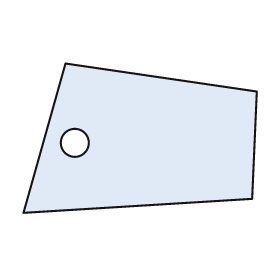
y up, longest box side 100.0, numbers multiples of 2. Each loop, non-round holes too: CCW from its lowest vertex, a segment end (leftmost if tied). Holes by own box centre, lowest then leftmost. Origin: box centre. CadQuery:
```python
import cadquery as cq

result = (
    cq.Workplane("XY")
    .moveTo(-50.0, -32.0)
    .lineTo(48.0, -26.0)
    .lineTo(50.0, 20.0)
    .lineTo(-32.0, 32.0)
    .close()
    .moveTo(-28.0, -2.0)
    .circle(6.0)
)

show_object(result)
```